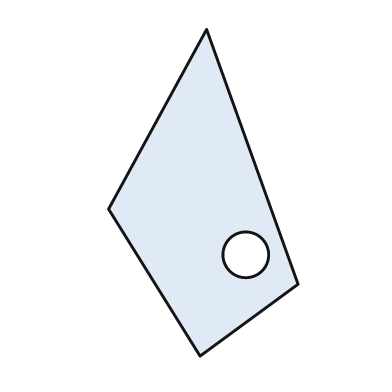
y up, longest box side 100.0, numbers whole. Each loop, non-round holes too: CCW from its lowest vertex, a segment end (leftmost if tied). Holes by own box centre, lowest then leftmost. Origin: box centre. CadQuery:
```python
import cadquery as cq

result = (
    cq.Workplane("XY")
    .moveTo(-1.0, -50.0)
    .lineTo(29.0, -28.0)
    .lineTo(1.0, 50.0)
    .lineTo(-29.0, -5.0)
    .close()
    .moveTo(13.0, -19.0)
    .circle(7.0)
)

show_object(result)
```